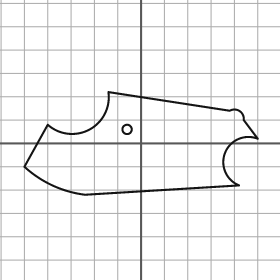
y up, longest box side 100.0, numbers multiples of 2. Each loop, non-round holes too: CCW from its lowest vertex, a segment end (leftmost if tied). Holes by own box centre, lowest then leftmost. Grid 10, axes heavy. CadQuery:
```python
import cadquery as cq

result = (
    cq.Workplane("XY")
    .moveTo(-24.0, -22.0)
    .lineTo(42.0, -18.0)
    .threePointArc((36.0, -4.0), (50.0, 2.0))
    .lineTo(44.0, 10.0)
    .threePointArc((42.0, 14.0), (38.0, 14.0))
    .lineTo(-14.0, 22.0)
    .threePointArc((-22.0, 6.0), (-40.0, 8.0))
    .lineTo(-50.0, -10.0)
    .threePointArc((-38.0, -18.0), (-24.0, -22.0))
    .close()
    .moveTo(-6.0, 6.0)
    .circle(2.0)
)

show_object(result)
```